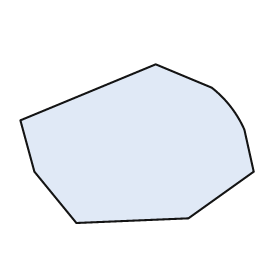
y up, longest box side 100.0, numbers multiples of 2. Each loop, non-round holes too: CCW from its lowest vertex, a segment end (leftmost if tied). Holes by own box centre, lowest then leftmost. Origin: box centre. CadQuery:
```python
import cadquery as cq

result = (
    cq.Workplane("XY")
    .moveTo(-26.0, -34.0)
    .lineTo(22.0, -32.0)
    .lineTo(50.0, -12.0)
    .lineTo(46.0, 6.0)
    .threePointArc((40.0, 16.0), (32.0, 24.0))
    .lineTo(8.0, 34.0)
    .lineTo(-50.0, 10.0)
    .lineTo(-44.0, -12.0)
    .close()
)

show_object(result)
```